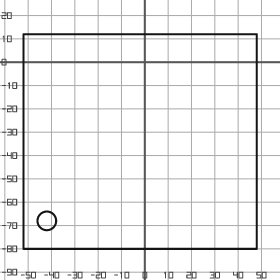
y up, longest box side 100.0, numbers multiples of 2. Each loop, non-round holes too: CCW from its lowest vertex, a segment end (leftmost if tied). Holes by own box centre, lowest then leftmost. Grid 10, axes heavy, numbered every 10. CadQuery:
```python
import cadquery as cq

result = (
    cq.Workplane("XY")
    .moveTo(-52.0, -80.0)
    .lineTo(48.0, -80.0)
    .lineTo(48.0, 12.0)
    .lineTo(-52.0, 12.0)
    .close()
    .moveTo(-42.0, -68.0)
    .circle(4.0)
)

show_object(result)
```